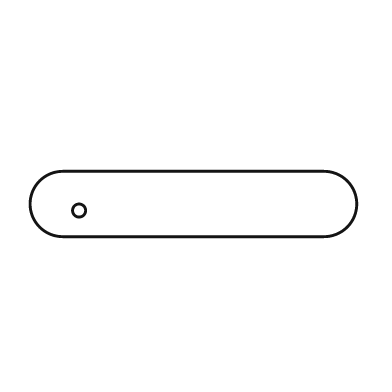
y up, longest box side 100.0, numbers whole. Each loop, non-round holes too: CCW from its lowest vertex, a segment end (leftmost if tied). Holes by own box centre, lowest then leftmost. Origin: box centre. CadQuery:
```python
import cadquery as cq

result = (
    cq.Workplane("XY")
    .moveTo(-40.0, -10.0)
    .lineTo(40.0, -10.0)
    .threePointArc((50.0, 0.0), (40.0, 10.0))
    .lineTo(-40.0, 10.0)
    .threePointArc((-50.0, 0.0), (-40.0, -10.0))
    .close()
    .moveTo(-35.0, -2.0)
    .circle(2.0)
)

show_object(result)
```